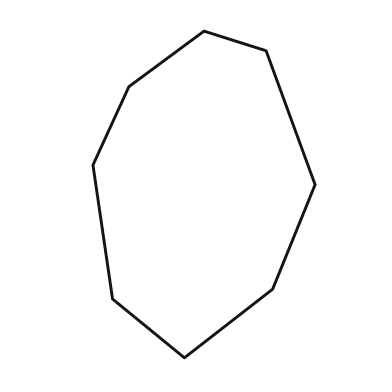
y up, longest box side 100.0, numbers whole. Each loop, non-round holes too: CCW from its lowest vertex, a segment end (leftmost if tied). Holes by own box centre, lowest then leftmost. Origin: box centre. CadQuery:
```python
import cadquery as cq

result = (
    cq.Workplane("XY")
    .moveTo(-6.0, -50.0)
    .lineTo(21.0, -29.0)
    .lineTo(34.0, 3.0)
    .lineTo(19.0, 44.0)
    .lineTo(0.0, 50.0)
    .lineTo(-23.0, 33.0)
    .lineTo(-34.0, 9.0)
    .lineTo(-28.0, -32.0)
    .close()
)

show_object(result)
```